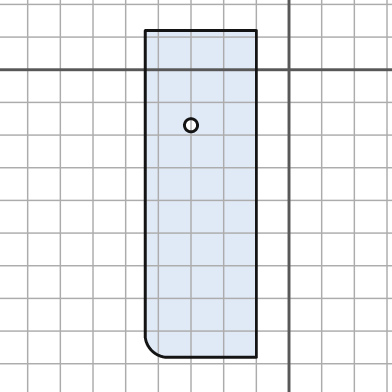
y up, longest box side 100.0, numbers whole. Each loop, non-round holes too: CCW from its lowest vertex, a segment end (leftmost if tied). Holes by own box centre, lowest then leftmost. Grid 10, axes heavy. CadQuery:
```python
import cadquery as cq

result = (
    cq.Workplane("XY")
    .moveTo(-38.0, -88.0)
    .lineTo(-10.0, -88.0)
    .lineTo(-10.0, 12.0)
    .lineTo(-44.0, 12.0)
    .lineTo(-44.0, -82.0)
    .threePointArc((-42.0, -86.0), (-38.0, -88.0))
    .close()
    .moveTo(-30.0, -17.0)
    .circle(2.0)
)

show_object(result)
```